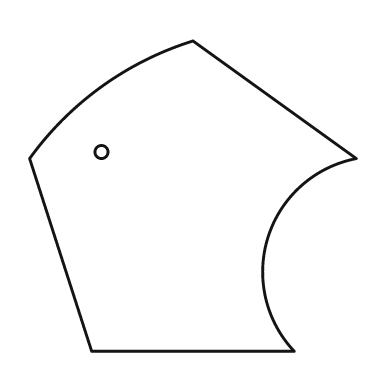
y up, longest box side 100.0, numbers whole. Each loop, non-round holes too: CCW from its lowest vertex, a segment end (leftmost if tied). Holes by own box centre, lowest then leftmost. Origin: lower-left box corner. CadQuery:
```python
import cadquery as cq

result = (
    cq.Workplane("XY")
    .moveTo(19.0, 0.0)
    .lineTo(81.0, 0.0)
    .threePointArc((73.0, 35.0), (100.0, 59.0))
    .lineTo(50.0, 95.0)
    .threePointArc((22.0, 81.0), (0.0, 59.0))
    .close()
    .moveTo(22.0, 61.0)
    .circle(2.0)
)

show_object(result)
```